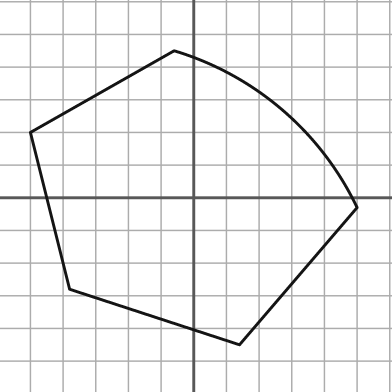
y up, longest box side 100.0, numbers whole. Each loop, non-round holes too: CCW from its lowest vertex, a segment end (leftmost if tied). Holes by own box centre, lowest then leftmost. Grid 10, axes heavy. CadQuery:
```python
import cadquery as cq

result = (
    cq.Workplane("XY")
    .moveTo(14.0, -45.0)
    .lineTo(50.0, -3.0)
    .threePointArc((27.0, 27.0), (-6.0, 45.0))
    .lineTo(-50.0, 20.0)
    .lineTo(-38.0, -28.0)
    .close()
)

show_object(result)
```